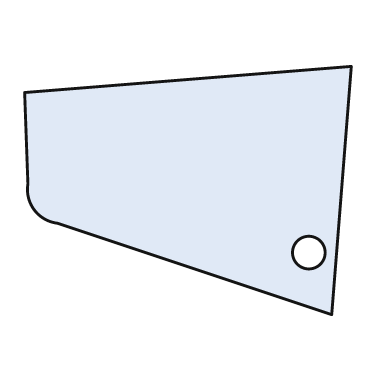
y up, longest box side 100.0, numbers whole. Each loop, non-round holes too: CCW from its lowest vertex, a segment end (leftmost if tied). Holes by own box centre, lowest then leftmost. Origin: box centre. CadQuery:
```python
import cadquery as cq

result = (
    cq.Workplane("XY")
    .moveTo(44.0, -38.0)
    .lineTo(50.0, 38.0)
    .lineTo(-50.0, 30.0)
    .lineTo(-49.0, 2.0)
    .threePointArc((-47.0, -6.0), (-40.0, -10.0))
    .close()
    .moveTo(37.0, -19.0)
    .circle(5.0)
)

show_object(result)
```